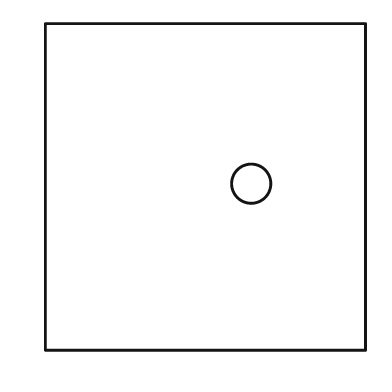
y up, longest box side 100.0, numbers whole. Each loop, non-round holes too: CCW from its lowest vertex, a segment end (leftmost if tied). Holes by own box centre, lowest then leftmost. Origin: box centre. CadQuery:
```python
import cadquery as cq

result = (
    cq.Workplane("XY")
    .moveTo(-49.0, -50.0)
    .lineTo(49.0, -50.0)
    .lineTo(49.0, 50.0)
    .lineTo(-49.0, 50.0)
    .close()
    .moveTo(14.0, 1.0)
    .circle(6.0)
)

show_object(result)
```